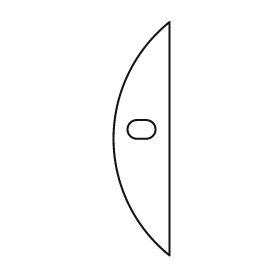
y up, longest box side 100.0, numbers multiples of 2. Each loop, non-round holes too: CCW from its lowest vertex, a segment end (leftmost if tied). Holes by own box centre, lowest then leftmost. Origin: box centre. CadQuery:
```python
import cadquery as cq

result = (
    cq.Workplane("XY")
    .moveTo(12.0, -50.0)
    .lineTo(12.0, 50.0)
    .threePointArc((-12.0, 0.0), (12.0, -50.0))
    .close()
    .moveTo(-2.0, 0.0)
    .lineTo(2.0, 0.0)
    .threePointArc((6.0, 4.0), (2.0, 8.0))
    .lineTo(-2.0, 8.0)
    .threePointArc((-6.0, 4.0), (-2.0, 0.0))
    .close()
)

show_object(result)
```